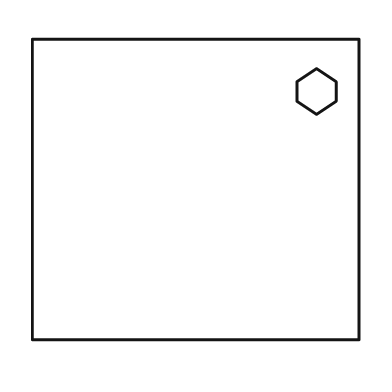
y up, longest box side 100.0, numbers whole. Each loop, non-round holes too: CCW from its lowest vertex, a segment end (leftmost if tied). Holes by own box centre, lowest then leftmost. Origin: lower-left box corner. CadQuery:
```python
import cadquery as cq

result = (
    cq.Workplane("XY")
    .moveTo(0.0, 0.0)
    .lineTo(100.0, 0.0)
    .lineTo(100.0, 92.0)
    .lineTo(0.0, 92.0)
    .close()
    .moveTo(87.0, 69.0)
    .lineTo(93.0, 73.0)
    .lineTo(93.0, 79.0)
    .lineTo(87.0, 83.0)
    .lineTo(81.0, 79.0)
    .lineTo(81.0, 73.0)
    .close()
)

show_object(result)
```